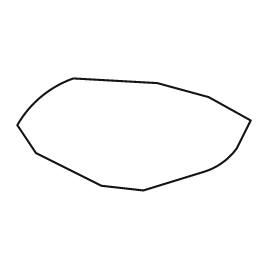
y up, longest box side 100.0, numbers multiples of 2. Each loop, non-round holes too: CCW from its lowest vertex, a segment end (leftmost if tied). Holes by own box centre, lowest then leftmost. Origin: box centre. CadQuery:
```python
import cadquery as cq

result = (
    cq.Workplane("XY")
    .moveTo(4.0, -24.0)
    .lineTo(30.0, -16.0)
    .threePointArc((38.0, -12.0), (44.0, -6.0))
    .lineTo(50.0, 6.0)
    .lineTo(32.0, 16.0)
    .lineTo(10.0, 22.0)
    .lineTo(-26.0, 24.0)
    .threePointArc((-40.0, 16.0), (-50.0, 4.0))
    .lineTo(-42.0, -8.0)
    .lineTo(-14.0, -22.0)
    .close()
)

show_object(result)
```